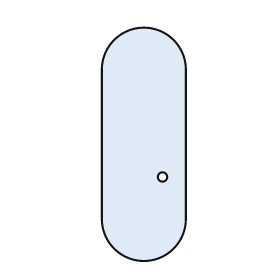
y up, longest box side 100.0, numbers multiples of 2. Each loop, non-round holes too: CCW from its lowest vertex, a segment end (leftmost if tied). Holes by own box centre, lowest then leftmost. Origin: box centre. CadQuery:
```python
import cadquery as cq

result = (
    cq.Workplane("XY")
    .moveTo(-18.0, -32.0)
    .threePointArc((0.0, -50.0), (18.0, -32.0))
    .lineTo(18.0, 32.0)
    .threePointArc((0.0, 50.0), (-18.0, 32.0))
    .close()
    .moveTo(8.0, -14.0)
    .circle(2.0)
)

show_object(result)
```